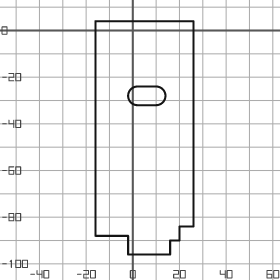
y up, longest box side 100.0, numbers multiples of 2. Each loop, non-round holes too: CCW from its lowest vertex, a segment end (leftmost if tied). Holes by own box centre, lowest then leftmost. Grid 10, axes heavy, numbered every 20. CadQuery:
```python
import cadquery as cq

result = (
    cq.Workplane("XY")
    .moveTo(-2.0, -96.0)
    .lineTo(16.0, -96.0)
    .lineTo(16.0, -90.0)
    .lineTo(20.0, -90.0)
    .lineTo(20.0, -84.0)
    .lineTo(26.0, -84.0)
    .lineTo(26.0, 4.0)
    .lineTo(-16.0, 4.0)
    .lineTo(-16.0, -88.0)
    .lineTo(-2.0, -88.0)
    .close()
    .moveTo(2.0, -32.0)
    .lineTo(10.0, -32.0)
    .threePointArc((14.0, -28.0), (10.0, -24.0))
    .lineTo(2.0, -24.0)
    .threePointArc((-2.0, -28.0), (2.0, -32.0))
    .close()
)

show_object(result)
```